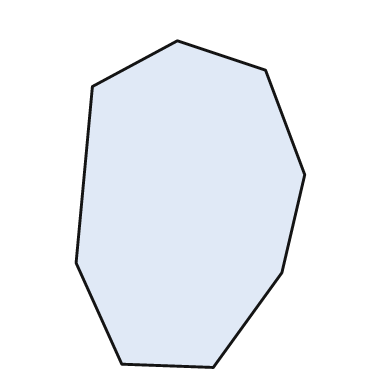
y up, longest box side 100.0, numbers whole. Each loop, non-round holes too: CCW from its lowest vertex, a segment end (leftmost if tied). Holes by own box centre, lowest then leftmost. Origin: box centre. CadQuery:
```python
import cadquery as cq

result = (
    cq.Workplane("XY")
    .moveTo(7.0, -50.0)
    .lineTo(28.0, -21.0)
    .lineTo(35.0, 9.0)
    .lineTo(23.0, 41.0)
    .lineTo(-4.0, 50.0)
    .lineTo(-30.0, 36.0)
    .lineTo(-35.0, -18.0)
    .lineTo(-21.0, -49.0)
    .close()
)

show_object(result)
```